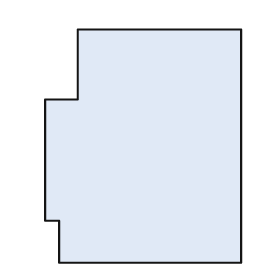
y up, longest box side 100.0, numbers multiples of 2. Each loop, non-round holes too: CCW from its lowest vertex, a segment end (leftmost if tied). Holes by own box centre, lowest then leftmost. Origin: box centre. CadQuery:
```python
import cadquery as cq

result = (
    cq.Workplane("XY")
    .moveTo(-36.0, -50.0)
    .lineTo(42.0, -50.0)
    .lineTo(42.0, 50.0)
    .lineTo(-28.0, 50.0)
    .lineTo(-28.0, 20.0)
    .lineTo(-42.0, 20.0)
    .lineTo(-42.0, -32.0)
    .lineTo(-36.0, -32.0)
    .close()
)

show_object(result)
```